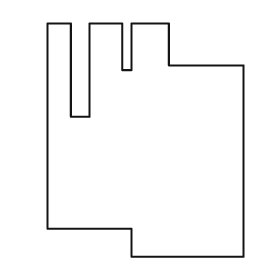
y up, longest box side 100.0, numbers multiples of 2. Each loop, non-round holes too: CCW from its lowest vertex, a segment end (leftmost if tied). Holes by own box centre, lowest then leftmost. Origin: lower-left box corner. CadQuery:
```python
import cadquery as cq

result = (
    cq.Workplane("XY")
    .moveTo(36.0, 0.0)
    .lineTo(84.0, 0.0)
    .lineTo(84.0, 82.0)
    .lineTo(52.0, 82.0)
    .lineTo(52.0, 100.0)
    .lineTo(36.0, 100.0)
    .lineTo(36.0, 80.0)
    .lineTo(32.0, 80.0)
    .lineTo(32.0, 100.0)
    .lineTo(18.0, 100.0)
    .lineTo(18.0, 60.0)
    .lineTo(10.0, 60.0)
    .lineTo(10.0, 100.0)
    .lineTo(0.0, 100.0)
    .lineTo(0.0, 12.0)
    .lineTo(36.0, 12.0)
    .close()
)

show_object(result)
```